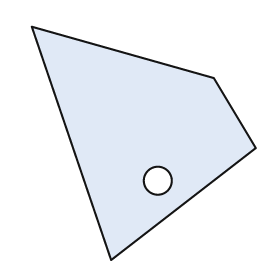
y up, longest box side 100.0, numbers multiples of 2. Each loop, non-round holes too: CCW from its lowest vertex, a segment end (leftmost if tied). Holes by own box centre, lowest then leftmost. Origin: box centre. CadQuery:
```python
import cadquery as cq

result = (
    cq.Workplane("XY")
    .moveTo(-14.0, -50.0)
    .lineTo(48.0, -2.0)
    .lineTo(30.0, 28.0)
    .lineTo(-48.0, 50.0)
    .close()
    .moveTo(6.0, -16.0)
    .circle(6.0)
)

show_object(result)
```